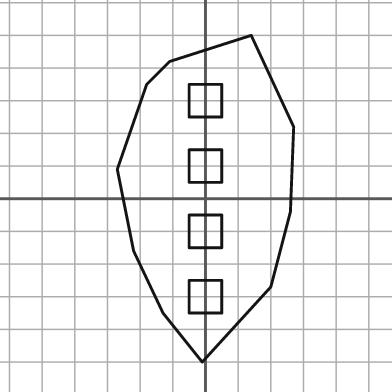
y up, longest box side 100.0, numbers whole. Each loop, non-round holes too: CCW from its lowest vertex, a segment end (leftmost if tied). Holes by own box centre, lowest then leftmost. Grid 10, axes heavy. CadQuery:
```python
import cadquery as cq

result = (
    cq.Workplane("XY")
    .moveTo(-1.0, -50.0)
    .lineTo(20.0, -27.0)
    .lineTo(26.0, -4.0)
    .lineTo(27.0, 22.0)
    .lineTo(14.0, 50.0)
    .lineTo(-11.0, 42.0)
    .lineTo(-18.0, 35.0)
    .lineTo(-27.0, 9.0)
    .lineTo(-22.0, -16.0)
    .lineTo(-13.0, -35.0)
    .close()
    .moveTo(-5.0, -35.0)
    .lineTo(5.0, -35.0)
    .lineTo(5.0, -25.0)
    .lineTo(-5.0, -25.0)
    .close()
    .moveTo(-5.0, -15.0)
    .lineTo(5.0, -15.0)
    .lineTo(5.0, -5.0)
    .lineTo(-5.0, -5.0)
    .close()
    .moveTo(-5.0, 5.0)
    .lineTo(5.0, 5.0)
    .lineTo(5.0, 15.0)
    .lineTo(-5.0, 15.0)
    .close()
    .moveTo(-5.0, 25.0)
    .lineTo(5.0, 25.0)
    .lineTo(5.0, 35.0)
    .lineTo(-5.0, 35.0)
    .close()
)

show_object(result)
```